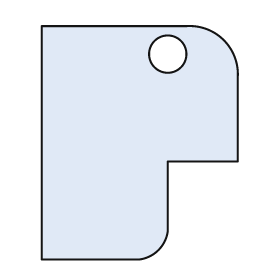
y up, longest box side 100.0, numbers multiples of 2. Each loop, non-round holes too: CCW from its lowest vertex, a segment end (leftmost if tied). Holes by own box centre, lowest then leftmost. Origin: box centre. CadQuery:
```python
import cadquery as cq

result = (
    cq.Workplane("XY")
    .moveTo(-42.0, -50.0)
    .lineTo(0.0, -50.0)
    .threePointArc((8.0, -46.0), (12.0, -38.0))
    .lineTo(12.0, -8.0)
    .lineTo(42.0, -8.0)
    .lineTo(42.0, 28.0)
    .threePointArc((36.0, 44.0), (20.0, 50.0))
    .lineTo(-42.0, 50.0)
    .close()
    .moveTo(12.0, 38.0)
    .circle(8.0)
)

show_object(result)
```